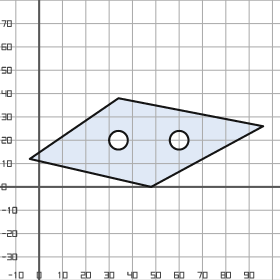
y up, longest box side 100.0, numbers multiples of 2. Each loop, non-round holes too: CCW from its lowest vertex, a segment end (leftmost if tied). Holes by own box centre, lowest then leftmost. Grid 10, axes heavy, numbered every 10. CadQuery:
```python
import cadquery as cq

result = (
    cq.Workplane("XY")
    .moveTo(48.0, 0.0)
    .lineTo(96.0, 26.0)
    .lineTo(34.0, 38.0)
    .lineTo(-4.0, 12.0)
    .close()
    .moveTo(34.0, 20.0)
    .circle(4.0)
    .moveTo(60.0, 20.0)
    .circle(4.0)
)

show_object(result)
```